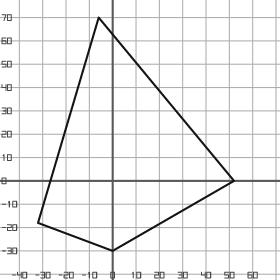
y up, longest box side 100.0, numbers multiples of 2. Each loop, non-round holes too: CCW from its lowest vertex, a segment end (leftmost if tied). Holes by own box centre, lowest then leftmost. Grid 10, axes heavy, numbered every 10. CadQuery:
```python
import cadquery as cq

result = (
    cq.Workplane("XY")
    .moveTo(0.0, -30.0)
    .lineTo(52.0, 0.0)
    .lineTo(-6.0, 70.0)
    .lineTo(-32.0, -18.0)
    .close()
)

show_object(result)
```